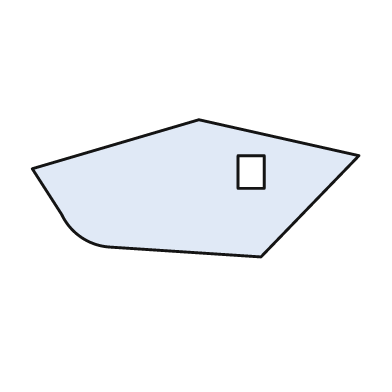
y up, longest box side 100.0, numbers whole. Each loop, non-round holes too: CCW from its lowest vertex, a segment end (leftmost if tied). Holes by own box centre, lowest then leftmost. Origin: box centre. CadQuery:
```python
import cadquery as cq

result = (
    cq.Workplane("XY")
    .moveTo(20.0, -21.0)
    .lineTo(50.0, 10.0)
    .lineTo(1.0, 21.0)
    .lineTo(-50.0, 6.0)
    .lineTo(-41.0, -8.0)
    .threePointArc((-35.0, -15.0), (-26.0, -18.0))
    .close()
    .moveTo(13.0, 0.0)
    .lineTo(21.0, 0.0)
    .lineTo(21.0, 10.0)
    .lineTo(13.0, 10.0)
    .close()
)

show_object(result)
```